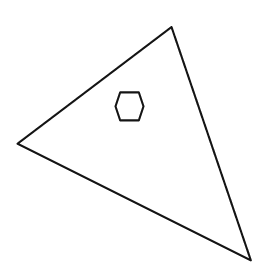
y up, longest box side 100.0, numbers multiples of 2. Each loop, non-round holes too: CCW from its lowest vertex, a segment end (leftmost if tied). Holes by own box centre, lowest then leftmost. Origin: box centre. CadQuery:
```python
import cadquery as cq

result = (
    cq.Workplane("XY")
    .moveTo(50.0, -50.0)
    .lineTo(16.0, 50.0)
    .lineTo(-50.0, 0.0)
    .close()
    .moveTo(-6.0, 10.0)
    .lineTo(2.0, 10.0)
    .lineTo(4.0, 16.0)
    .lineTo(2.0, 22.0)
    .lineTo(-6.0, 22.0)
    .lineTo(-8.0, 16.0)
    .close()
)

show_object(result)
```